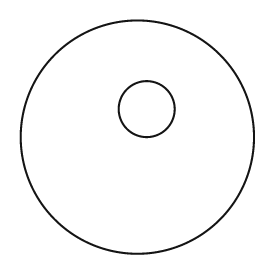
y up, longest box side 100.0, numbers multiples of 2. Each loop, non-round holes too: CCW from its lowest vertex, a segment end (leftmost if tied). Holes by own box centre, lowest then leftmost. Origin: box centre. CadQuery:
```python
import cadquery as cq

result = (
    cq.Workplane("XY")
    .moveTo(0.0, 0.0)
    .circle(50.0)
    .moveTo(4.0, 12.0)
    .circle(12.0)
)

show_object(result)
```